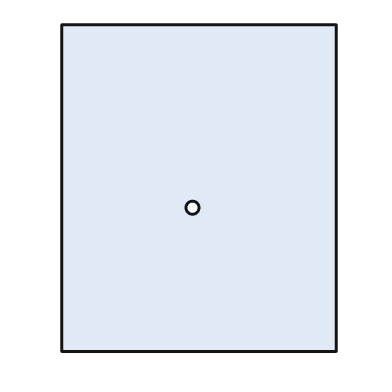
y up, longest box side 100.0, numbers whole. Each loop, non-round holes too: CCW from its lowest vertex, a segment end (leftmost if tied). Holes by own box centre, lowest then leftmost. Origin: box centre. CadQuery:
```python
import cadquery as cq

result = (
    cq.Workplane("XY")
    .moveTo(-42.0, -50.0)
    .lineTo(42.0, -50.0)
    .lineTo(42.0, 50.0)
    .lineTo(-42.0, 50.0)
    .close()
    .moveTo(-2.0, -6.0)
    .circle(2.0)
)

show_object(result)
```